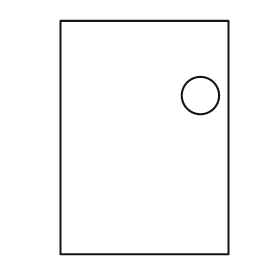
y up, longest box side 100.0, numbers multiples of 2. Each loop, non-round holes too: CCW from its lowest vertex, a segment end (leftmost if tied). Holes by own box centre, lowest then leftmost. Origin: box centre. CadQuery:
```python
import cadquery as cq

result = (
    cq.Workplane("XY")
    .moveTo(-36.0, -50.0)
    .lineTo(36.0, -50.0)
    .lineTo(36.0, 50.0)
    .lineTo(-36.0, 50.0)
    .close()
    .moveTo(24.0, 18.0)
    .circle(8.0)
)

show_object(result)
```